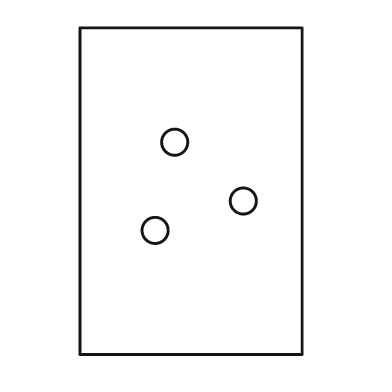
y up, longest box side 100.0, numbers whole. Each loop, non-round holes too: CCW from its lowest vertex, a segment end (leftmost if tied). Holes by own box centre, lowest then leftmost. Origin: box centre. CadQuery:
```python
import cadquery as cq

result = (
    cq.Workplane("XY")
    .moveTo(-34.0, -50.0)
    .lineTo(34.0, -50.0)
    .lineTo(34.0, 50.0)
    .lineTo(-34.0, 50.0)
    .close()
    .moveTo(-11.0, -12.0)
    .circle(4.0)
    .moveTo(16.0, -3.0)
    .circle(4.0)
    .moveTo(-5.0, 15.0)
    .circle(4.0)
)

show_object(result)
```